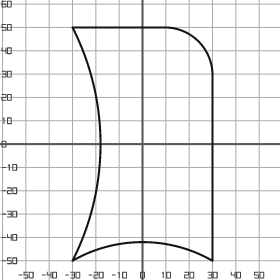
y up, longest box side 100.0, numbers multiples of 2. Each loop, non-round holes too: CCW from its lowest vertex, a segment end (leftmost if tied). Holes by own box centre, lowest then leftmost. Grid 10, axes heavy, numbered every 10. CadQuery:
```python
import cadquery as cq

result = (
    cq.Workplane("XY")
    .moveTo(-30.0, -50.0)
    .threePointArc((0.0, -42.0), (30.0, -50.0))
    .lineTo(30.0, 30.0)
    .threePointArc((24.0, 44.0), (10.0, 50.0))
    .lineTo(-30.0, 50.0)
    .threePointArc((-18.0, 0.0), (-30.0, -50.0))
    .close()
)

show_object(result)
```